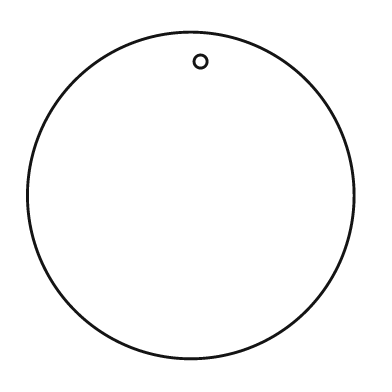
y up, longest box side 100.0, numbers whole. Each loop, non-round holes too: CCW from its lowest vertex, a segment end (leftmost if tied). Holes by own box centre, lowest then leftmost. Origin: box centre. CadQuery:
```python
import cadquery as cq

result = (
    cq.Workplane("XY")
    .moveTo(0.0, 0.0)
    .circle(50.0)
    .moveTo(3.0, 41.0)
    .circle(2.0)
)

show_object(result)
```